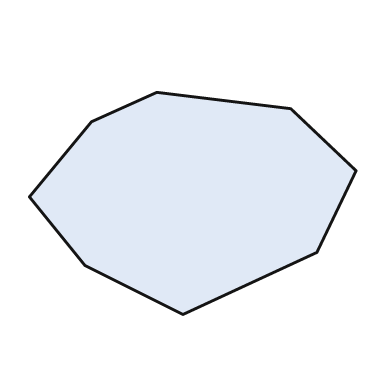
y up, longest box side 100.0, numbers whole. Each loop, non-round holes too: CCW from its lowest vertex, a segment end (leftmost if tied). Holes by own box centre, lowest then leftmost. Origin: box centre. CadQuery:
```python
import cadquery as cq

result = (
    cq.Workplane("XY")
    .moveTo(-3.0, -34.0)
    .lineTo(38.0, -15.0)
    .lineTo(50.0, 10.0)
    .lineTo(30.0, 29.0)
    .lineTo(-11.0, 34.0)
    .lineTo(-31.0, 25.0)
    .lineTo(-50.0, 2.0)
    .lineTo(-33.0, -19.0)
    .close()
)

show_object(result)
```